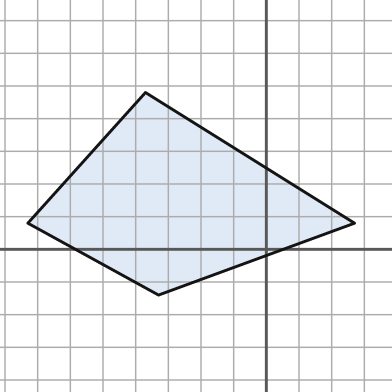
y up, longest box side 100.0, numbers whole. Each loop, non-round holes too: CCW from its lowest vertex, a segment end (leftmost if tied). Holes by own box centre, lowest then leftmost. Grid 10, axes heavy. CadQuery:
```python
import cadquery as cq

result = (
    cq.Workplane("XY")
    .moveTo(-33.0, -14.0)
    .lineTo(27.0, 8.0)
    .lineTo(-37.0, 48.0)
    .lineTo(-73.0, 8.0)
    .close()
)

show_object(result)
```